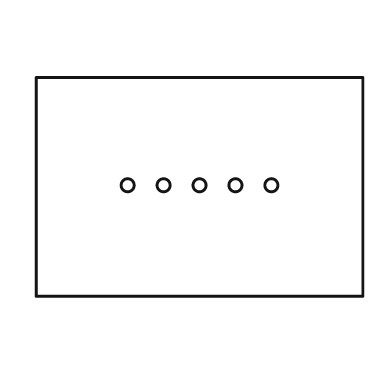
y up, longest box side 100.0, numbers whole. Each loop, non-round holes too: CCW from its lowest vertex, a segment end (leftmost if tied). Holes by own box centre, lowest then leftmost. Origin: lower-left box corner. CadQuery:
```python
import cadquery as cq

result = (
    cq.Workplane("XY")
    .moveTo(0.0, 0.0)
    .lineTo(100.0, 0.0)
    .lineTo(100.0, 67.0)
    .lineTo(0.0, 67.0)
    .close()
    .moveTo(28.0, 34.0)
    .circle(2.0)
    .moveTo(39.0, 34.0)
    .circle(2.0)
    .moveTo(50.0, 34.0)
    .circle(2.0)
    .moveTo(61.0, 34.0)
    .circle(2.0)
    .moveTo(72.0, 34.0)
    .circle(2.0)
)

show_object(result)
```